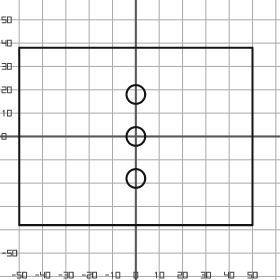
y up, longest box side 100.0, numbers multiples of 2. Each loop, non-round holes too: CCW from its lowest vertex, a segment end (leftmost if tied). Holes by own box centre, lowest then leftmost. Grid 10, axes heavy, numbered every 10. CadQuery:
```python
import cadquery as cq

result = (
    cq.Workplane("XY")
    .moveTo(-50.0, -38.0)
    .lineTo(50.0, -38.0)
    .lineTo(50.0, 38.0)
    .lineTo(-50.0, 38.0)
    .close()
    .moveTo(0.0, -18.0)
    .circle(4.0)
    .moveTo(0.0, 0.0)
    .circle(4.0)
    .moveTo(0.0, 18.0)
    .circle(4.0)
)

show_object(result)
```